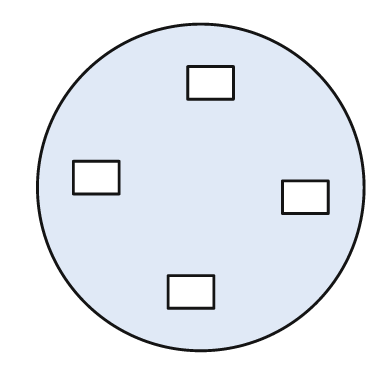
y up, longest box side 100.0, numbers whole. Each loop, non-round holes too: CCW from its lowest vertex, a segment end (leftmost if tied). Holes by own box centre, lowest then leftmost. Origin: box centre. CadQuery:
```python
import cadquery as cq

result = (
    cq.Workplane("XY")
    .moveTo(0.0, 0.0)
    .circle(50.0)
    .moveTo(-10.0, -37.0)
    .lineTo(4.0, -37.0)
    .lineTo(4.0, -27.0)
    .lineTo(-10.0, -27.0)
    .close()
    .moveTo(25.0, -8.0)
    .lineTo(39.0, -8.0)
    .lineTo(39.0, 2.0)
    .lineTo(25.0, 2.0)
    .close()
    .moveTo(-39.0, -2.0)
    .lineTo(-25.0, -2.0)
    .lineTo(-25.0, 8.0)
    .lineTo(-39.0, 8.0)
    .close()
    .moveTo(-4.0, 27.0)
    .lineTo(10.0, 27.0)
    .lineTo(10.0, 37.0)
    .lineTo(-4.0, 37.0)
    .close()
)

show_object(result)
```